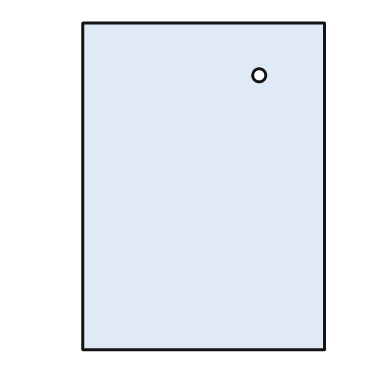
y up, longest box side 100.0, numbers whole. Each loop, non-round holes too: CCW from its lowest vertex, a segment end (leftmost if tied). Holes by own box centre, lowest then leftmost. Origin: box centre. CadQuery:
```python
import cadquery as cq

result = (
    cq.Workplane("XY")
    .moveTo(-37.0, -50.0)
    .lineTo(37.0, -50.0)
    .lineTo(37.0, 50.0)
    .lineTo(-37.0, 50.0)
    .close()
    .moveTo(17.0, 34.0)
    .circle(2.0)
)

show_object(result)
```